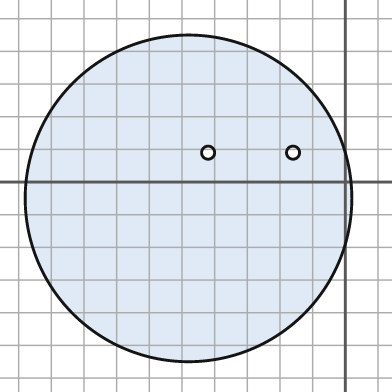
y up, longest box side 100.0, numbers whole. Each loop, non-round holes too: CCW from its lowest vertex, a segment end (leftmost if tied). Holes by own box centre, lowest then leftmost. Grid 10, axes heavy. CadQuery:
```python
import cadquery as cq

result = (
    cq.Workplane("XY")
    .moveTo(-48.0, -5.0)
    .circle(50.0)
    .moveTo(-42.0, 9.0)
    .circle(2.0)
    .moveTo(-16.0, 9.0)
    .circle(2.0)
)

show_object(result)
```